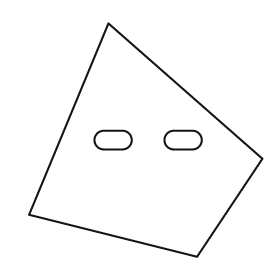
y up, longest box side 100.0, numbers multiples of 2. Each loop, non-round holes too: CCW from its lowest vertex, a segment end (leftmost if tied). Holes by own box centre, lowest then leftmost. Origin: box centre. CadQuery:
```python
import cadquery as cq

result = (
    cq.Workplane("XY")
    .moveTo(22.0, -50.0)
    .lineTo(50.0, -8.0)
    .lineTo(-16.0, 50.0)
    .lineTo(-50.0, -32.0)
    .close()
    .moveTo(-18.0, -4.0)
    .lineTo(-10.0, -4.0)
    .threePointArc((-6.0, 0.0), (-10.0, 4.0))
    .lineTo(-18.0, 4.0)
    .threePointArc((-22.0, 0.0), (-18.0, -4.0))
    .close()
    .moveTo(12.0, -4.0)
    .lineTo(20.0, -4.0)
    .threePointArc((24.0, 0.0), (20.0, 4.0))
    .lineTo(12.0, 4.0)
    .threePointArc((8.0, 0.0), (12.0, -4.0))
    .close()
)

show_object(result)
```